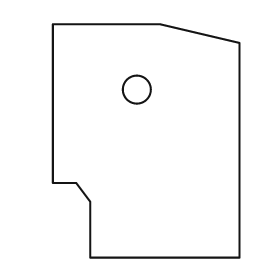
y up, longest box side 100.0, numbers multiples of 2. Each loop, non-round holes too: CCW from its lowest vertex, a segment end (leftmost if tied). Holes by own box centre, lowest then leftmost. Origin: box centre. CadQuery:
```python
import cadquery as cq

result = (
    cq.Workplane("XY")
    .moveTo(-24.0, -50.0)
    .lineTo(40.0, -50.0)
    .lineTo(40.0, 42.0)
    .lineTo(6.0, 50.0)
    .lineTo(-40.0, 50.0)
    .lineTo(-40.0, -18.0)
    .lineTo(-30.0, -18.0)
    .lineTo(-24.0, -26.0)
    .close()
    .moveTo(-4.0, 22.0)
    .circle(6.0)
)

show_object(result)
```